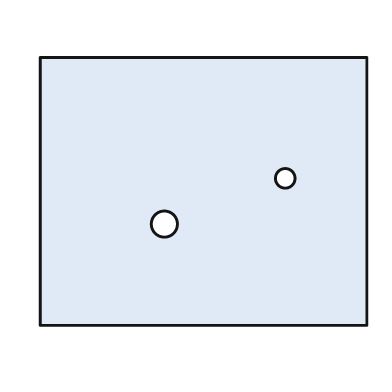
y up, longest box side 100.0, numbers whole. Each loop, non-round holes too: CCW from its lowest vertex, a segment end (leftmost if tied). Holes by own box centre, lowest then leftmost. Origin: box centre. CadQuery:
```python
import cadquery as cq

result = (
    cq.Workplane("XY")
    .moveTo(-50.0, -41.0)
    .lineTo(50.0, -41.0)
    .lineTo(50.0, 41.0)
    .lineTo(-50.0, 41.0)
    .close()
    .moveTo(-12.0, -10.0)
    .circle(4.0)
    .moveTo(25.0, 4.0)
    .circle(3.0)
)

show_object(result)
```